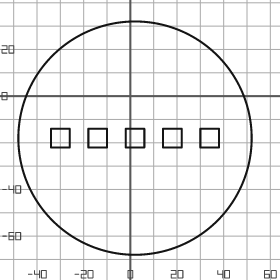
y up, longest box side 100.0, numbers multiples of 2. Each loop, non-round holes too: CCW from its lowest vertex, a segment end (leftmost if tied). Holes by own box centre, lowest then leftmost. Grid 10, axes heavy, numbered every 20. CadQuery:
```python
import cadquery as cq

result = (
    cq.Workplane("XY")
    .moveTo(2.0, -18.0)
    .circle(50.0)
    .moveTo(-34.0, -22.0)
    .lineTo(-26.0, -22.0)
    .lineTo(-26.0, -14.0)
    .lineTo(-34.0, -14.0)
    .close()
    .moveTo(-18.0, -22.0)
    .lineTo(-10.0, -22.0)
    .lineTo(-10.0, -14.0)
    .lineTo(-18.0, -14.0)
    .close()
    .moveTo(-2.0, -22.0)
    .lineTo(6.0, -22.0)
    .lineTo(6.0, -14.0)
    .lineTo(-2.0, -14.0)
    .close()
    .moveTo(14.0, -22.0)
    .lineTo(22.0, -22.0)
    .lineTo(22.0, -14.0)
    .lineTo(14.0, -14.0)
    .close()
    .moveTo(30.0, -22.0)
    .lineTo(38.0, -22.0)
    .lineTo(38.0, -14.0)
    .lineTo(30.0, -14.0)
    .close()
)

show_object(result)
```